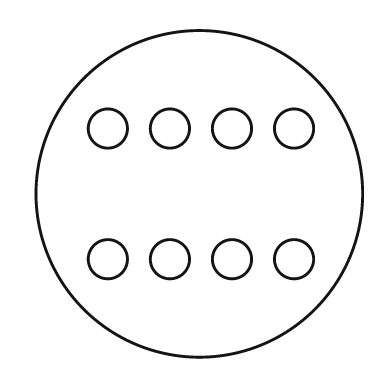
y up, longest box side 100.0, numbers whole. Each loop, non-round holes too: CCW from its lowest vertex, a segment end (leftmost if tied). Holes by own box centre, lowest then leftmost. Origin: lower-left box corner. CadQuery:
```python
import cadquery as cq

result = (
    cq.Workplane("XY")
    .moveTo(50.0, 50.0)
    .circle(50.0)
    .moveTo(22.0, 30.0)
    .circle(6.0)
    .moveTo(41.0, 30.0)
    .circle(6.0)
    .moveTo(60.0, 30.0)
    .circle(6.0)
    .moveTo(79.0, 30.0)
    .circle(6.0)
    .moveTo(22.0, 70.0)
    .circle(6.0)
    .moveTo(41.0, 70.0)
    .circle(6.0)
    .moveTo(60.0, 70.0)
    .circle(6.0)
    .moveTo(79.0, 70.0)
    .circle(6.0)
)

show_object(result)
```